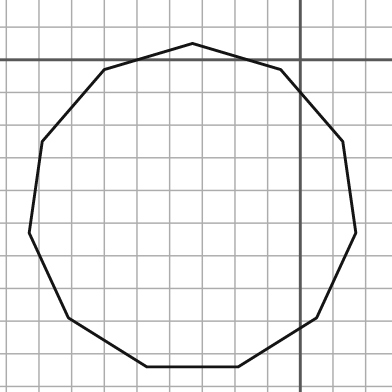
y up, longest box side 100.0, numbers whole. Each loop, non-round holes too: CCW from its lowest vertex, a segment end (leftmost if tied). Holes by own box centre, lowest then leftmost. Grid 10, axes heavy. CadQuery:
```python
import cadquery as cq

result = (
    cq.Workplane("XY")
    .moveTo(-47.0, -94.0)
    .lineTo(-19.0, -94.0)
    .lineTo(5.0, -79.0)
    .lineTo(17.0, -53.0)
    .lineTo(13.0, -25.0)
    .lineTo(-6.0, -3.0)
    .lineTo(-33.0, 5.0)
    .lineTo(-60.0, -3.0)
    .lineTo(-79.0, -25.0)
    .lineTo(-83.0, -53.0)
    .lineTo(-71.0, -79.0)
    .close()
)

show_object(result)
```